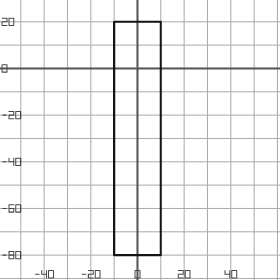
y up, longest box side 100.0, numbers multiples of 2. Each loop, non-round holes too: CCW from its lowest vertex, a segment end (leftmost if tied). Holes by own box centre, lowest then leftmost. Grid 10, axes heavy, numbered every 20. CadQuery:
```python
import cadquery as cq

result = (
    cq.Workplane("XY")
    .moveTo(-10.0, -80.0)
    .lineTo(10.0, -80.0)
    .lineTo(10.0, 20.0)
    .lineTo(-10.0, 20.0)
    .close()
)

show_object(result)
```